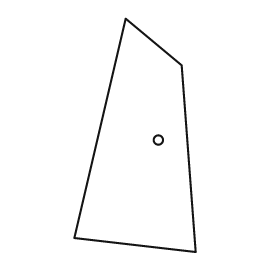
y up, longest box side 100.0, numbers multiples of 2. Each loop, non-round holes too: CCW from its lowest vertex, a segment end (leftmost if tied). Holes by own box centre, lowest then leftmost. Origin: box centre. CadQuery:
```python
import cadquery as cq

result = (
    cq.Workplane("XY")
    .moveTo(26.0, -50.0)
    .lineTo(20.0, 30.0)
    .lineTo(-4.0, 50.0)
    .lineTo(-26.0, -44.0)
    .close()
    .moveTo(10.0, -2.0)
    .circle(2.0)
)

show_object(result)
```